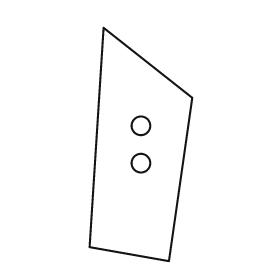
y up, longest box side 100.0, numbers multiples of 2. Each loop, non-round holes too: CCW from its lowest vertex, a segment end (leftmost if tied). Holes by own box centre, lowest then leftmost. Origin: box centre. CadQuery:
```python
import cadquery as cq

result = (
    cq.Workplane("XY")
    .moveTo(12.0, -50.0)
    .lineTo(22.0, 20.0)
    .lineTo(-16.0, 50.0)
    .lineTo(-22.0, -44.0)
    .close()
    .moveTo(0.0, -8.0)
    .circle(4.0)
    .moveTo(0.0, 8.0)
    .circle(4.0)
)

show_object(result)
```